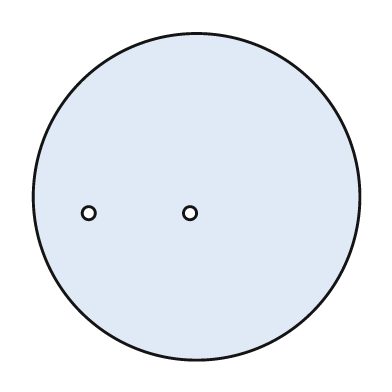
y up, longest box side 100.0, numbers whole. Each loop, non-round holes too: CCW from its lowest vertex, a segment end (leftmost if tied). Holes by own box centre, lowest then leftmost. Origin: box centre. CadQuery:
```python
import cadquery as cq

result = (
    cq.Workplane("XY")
    .moveTo(0.0, 0.0)
    .circle(50.0)
    .moveTo(-33.0, -5.0)
    .circle(2.0)
    .moveTo(-2.0, -5.0)
    .circle(2.0)
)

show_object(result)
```